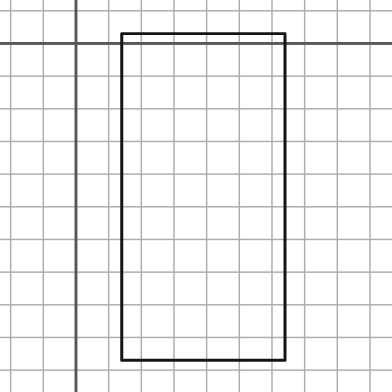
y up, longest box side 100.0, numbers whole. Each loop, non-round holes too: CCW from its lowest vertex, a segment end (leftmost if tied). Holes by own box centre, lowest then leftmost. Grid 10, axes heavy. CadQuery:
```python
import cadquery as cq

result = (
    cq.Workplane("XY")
    .moveTo(14.0, -97.0)
    .lineTo(64.0, -97.0)
    .lineTo(64.0, 3.0)
    .lineTo(14.0, 3.0)
    .close()
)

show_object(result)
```